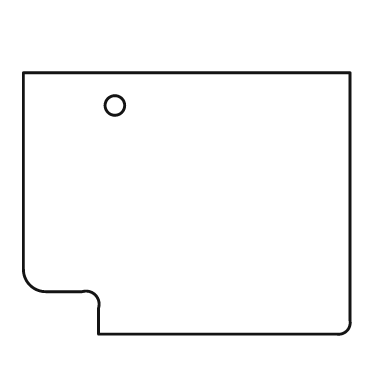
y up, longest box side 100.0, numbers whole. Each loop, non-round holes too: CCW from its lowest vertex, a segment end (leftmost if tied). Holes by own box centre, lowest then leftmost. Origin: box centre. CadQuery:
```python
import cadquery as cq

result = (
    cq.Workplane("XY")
    .moveTo(-27.0, -40.0)
    .lineTo(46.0, -40.0)
    .threePointArc((49.0, -39.0), (50.0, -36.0))
    .lineTo(50.0, 40.0)
    .lineTo(-50.0, 40.0)
    .lineTo(-50.0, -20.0)
    .threePointArc((-48.0, -25.0), (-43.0, -27.0))
    .lineTo(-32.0, -27.0)
    .threePointArc((-28.0, -28.0), (-27.0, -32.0))
    .close()
    .moveTo(-22.0, 30.0)
    .circle(3.0)
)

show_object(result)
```